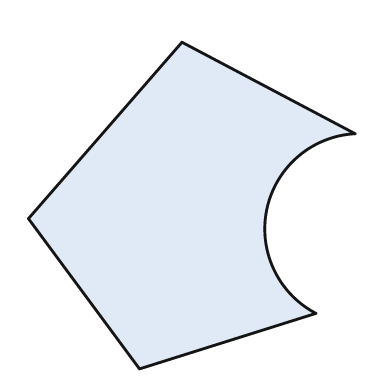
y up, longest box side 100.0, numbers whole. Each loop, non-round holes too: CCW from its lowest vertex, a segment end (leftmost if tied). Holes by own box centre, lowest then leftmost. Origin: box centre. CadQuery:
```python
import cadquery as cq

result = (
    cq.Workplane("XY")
    .moveTo(-16.0, -50.0)
    .lineTo(38.0, -33.0)
    .threePointArc((23.0, -1.0), (50.0, 22.0))
    .lineTo(-3.0, 50.0)
    .lineTo(-50.0, -4.0)
    .close()
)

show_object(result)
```